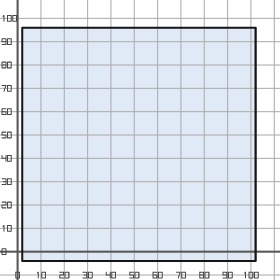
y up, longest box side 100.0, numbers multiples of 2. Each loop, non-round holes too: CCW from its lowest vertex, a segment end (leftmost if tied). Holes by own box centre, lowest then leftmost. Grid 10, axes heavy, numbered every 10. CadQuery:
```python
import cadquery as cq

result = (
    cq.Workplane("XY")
    .moveTo(2.0, -4.0)
    .lineTo(102.0, -4.0)
    .lineTo(102.0, 96.0)
    .lineTo(2.0, 96.0)
    .close()
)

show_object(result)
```